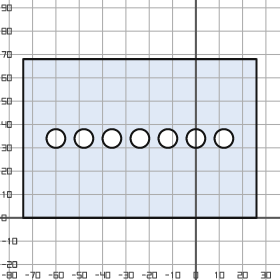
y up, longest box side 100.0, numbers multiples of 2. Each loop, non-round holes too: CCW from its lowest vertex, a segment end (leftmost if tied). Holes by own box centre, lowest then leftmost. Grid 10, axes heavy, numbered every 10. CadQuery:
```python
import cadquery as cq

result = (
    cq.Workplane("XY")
    .moveTo(-74.0, 0.0)
    .lineTo(26.0, 0.0)
    .lineTo(26.0, 68.0)
    .lineTo(-74.0, 68.0)
    .close()
    .moveTo(-60.0, 34.0)
    .circle(4.0)
    .moveTo(-48.0, 34.0)
    .circle(4.0)
    .moveTo(-36.0, 34.0)
    .circle(4.0)
    .moveTo(-24.0, 34.0)
    .circle(4.0)
    .moveTo(-12.0, 34.0)
    .circle(4.0)
    .moveTo(0.0, 34.0)
    .circle(4.0)
    .moveTo(12.0, 34.0)
    .circle(4.0)
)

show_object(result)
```